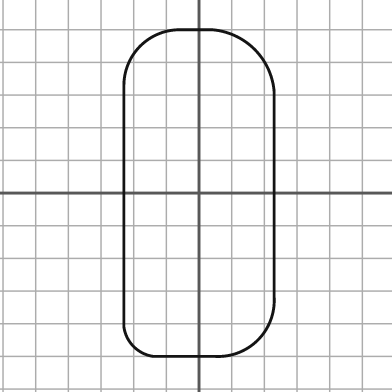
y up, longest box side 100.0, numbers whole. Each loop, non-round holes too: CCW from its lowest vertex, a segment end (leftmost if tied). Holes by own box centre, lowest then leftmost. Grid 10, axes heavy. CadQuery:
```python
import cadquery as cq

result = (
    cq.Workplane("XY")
    .moveTo(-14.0, -50.0)
    .lineTo(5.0, -50.0)
    .threePointArc((18.0, -45.0), (23.0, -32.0))
    .lineTo(23.0, 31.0)
    .threePointArc((17.0, 44.0), (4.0, 50.0))
    .lineTo(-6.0, 50.0)
    .threePointArc((-18.0, 45.0), (-23.0, 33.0))
    .lineTo(-23.0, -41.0)
    .threePointArc((-20.0, -47.0), (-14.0, -50.0))
    .close()
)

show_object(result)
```